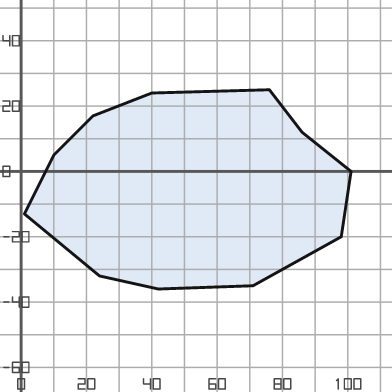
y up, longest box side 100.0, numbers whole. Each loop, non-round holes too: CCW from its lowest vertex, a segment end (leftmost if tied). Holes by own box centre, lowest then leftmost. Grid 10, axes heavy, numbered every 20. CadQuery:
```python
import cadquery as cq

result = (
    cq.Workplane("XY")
    .moveTo(42.0, -36.0)
    .lineTo(71.0, -35.0)
    .lineTo(98.0, -20.0)
    .lineTo(101.0, 0.0)
    .lineTo(86.0, 12.0)
    .lineTo(76.0, 25.0)
    .lineTo(40.0, 24.0)
    .lineTo(22.0, 17.0)
    .lineTo(10.0, 5.0)
    .lineTo(1.0, -13.0)
    .lineTo(24.0, -32.0)
    .close()
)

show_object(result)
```